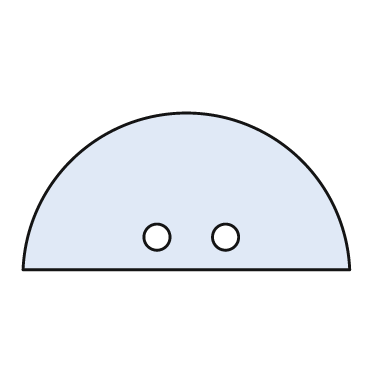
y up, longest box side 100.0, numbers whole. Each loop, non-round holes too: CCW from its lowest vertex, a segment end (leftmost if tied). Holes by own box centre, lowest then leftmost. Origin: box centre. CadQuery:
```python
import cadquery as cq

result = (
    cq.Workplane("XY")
    .moveTo(-50.0, -24.0)
    .lineTo(50.0, -24.0)
    .threePointArc((0.0, 24.0), (-50.0, -24.0))
    .close()
    .moveTo(-9.0, -14.0)
    .circle(4.0)
    .moveTo(12.0, -14.0)
    .circle(4.0)
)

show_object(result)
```